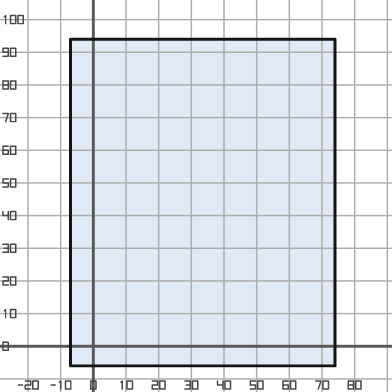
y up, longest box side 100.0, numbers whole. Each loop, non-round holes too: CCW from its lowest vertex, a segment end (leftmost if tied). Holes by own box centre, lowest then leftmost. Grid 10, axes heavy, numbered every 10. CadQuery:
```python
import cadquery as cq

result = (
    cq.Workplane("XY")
    .moveTo(-7.0, -6.0)
    .lineTo(74.0, -6.0)
    .lineTo(74.0, 94.0)
    .lineTo(-7.0, 94.0)
    .close()
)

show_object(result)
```